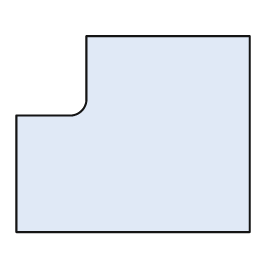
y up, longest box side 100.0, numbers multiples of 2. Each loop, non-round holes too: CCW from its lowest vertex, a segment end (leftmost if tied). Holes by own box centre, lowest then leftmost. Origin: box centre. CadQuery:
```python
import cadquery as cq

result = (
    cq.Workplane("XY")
    .moveTo(-50.0, -42.0)
    .lineTo(50.0, -42.0)
    .lineTo(50.0, 42.0)
    .lineTo(-20.0, 42.0)
    .lineTo(-20.0, 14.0)
    .threePointArc((-22.0, 10.0), (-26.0, 8.0))
    .lineTo(-50.0, 8.0)
    .close()
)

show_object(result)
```